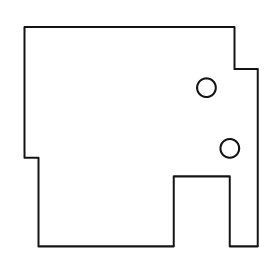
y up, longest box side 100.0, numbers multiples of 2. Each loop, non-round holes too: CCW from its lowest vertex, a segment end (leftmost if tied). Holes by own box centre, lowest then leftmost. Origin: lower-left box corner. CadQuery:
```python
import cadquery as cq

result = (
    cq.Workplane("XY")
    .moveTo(6.0, 0.0)
    .lineTo(64.0, 0.0)
    .lineTo(64.0, 30.0)
    .lineTo(88.0, 30.0)
    .lineTo(88.0, 0.0)
    .lineTo(100.0, 0.0)
    .lineTo(100.0, 76.0)
    .lineTo(90.0, 76.0)
    .lineTo(90.0, 94.0)
    .lineTo(0.0, 94.0)
    .lineTo(0.0, 38.0)
    .lineTo(6.0, 38.0)
    .close()
    .moveTo(88.0, 42.0)
    .circle(4.0)
    .moveTo(78.0, 68.0)
    .circle(4.0)
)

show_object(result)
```